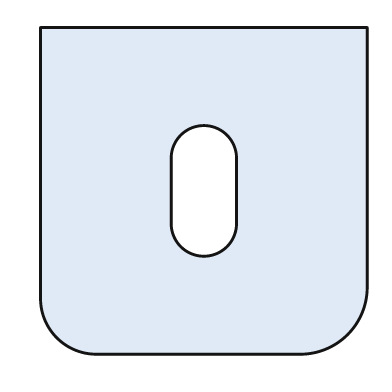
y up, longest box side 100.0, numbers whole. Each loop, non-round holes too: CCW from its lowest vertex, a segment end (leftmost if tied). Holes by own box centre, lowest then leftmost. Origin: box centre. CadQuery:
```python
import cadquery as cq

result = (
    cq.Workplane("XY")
    .moveTo(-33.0, -50.0)
    .lineTo(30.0, -50.0)
    .threePointArc((44.0, -44.0), (50.0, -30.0))
    .lineTo(50.0, 50.0)
    .lineTo(-50.0, 50.0)
    .lineTo(-50.0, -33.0)
    .threePointArc((-45.0, -45.0), (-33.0, -50.0))
    .close()
    .moveTo(-10.0, -10.0)
    .threePointArc((0.0, -20.0), (10.0, -10.0))
    .lineTo(10.0, 10.0)
    .threePointArc((0.0, 20.0), (-10.0, 10.0))
    .close()
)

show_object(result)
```